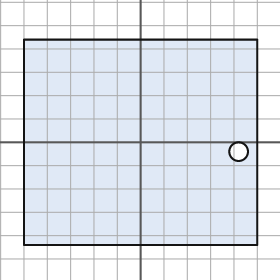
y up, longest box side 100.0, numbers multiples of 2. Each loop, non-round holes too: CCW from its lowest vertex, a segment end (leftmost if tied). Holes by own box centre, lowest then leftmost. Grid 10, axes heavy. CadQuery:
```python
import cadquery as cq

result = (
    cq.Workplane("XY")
    .moveTo(-50.0, -44.0)
    .lineTo(50.0, -44.0)
    .lineTo(50.0, 44.0)
    .lineTo(-50.0, 44.0)
    .close()
    .moveTo(42.0, -4.0)
    .circle(4.0)
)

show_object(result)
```